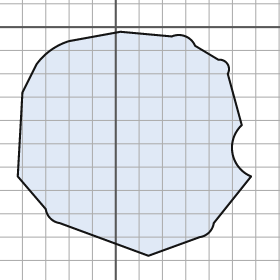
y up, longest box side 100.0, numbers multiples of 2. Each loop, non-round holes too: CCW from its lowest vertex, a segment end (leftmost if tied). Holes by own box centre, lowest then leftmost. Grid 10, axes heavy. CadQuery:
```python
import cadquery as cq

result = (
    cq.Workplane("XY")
    .moveTo(14.0, -98.0)
    .lineTo(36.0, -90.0)
    .threePointArc((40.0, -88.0), (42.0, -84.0))
    .lineTo(58.0, -64.0)
    .threePointArc((50.0, -54.0), (54.0, -42.0))
    .lineTo(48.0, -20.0)
    .threePointArc((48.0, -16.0), (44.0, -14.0))
    .lineTo(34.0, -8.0)
    .threePointArc((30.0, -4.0), (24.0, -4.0))
    .lineTo(2.0, -2.0)
    .lineTo(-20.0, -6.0)
    .threePointArc((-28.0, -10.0), (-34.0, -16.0))
    .lineTo(-40.0, -28.0)
    .lineTo(-42.0, -64.0)
    .lineTo(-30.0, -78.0)
    .threePointArc((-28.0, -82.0), (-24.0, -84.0))
    .close()
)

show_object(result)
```